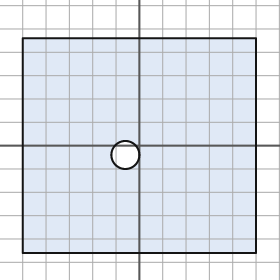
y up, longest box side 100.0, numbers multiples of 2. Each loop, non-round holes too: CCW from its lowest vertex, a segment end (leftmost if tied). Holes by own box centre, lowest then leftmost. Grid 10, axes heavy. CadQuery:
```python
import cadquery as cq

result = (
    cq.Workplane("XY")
    .moveTo(-50.0, -46.0)
    .lineTo(50.0, -46.0)
    .lineTo(50.0, 46.0)
    .lineTo(-50.0, 46.0)
    .close()
    .moveTo(-6.0, -4.0)
    .circle(6.0)
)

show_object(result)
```